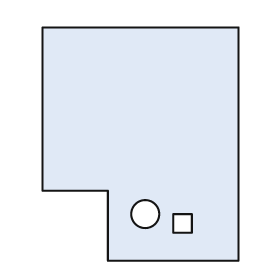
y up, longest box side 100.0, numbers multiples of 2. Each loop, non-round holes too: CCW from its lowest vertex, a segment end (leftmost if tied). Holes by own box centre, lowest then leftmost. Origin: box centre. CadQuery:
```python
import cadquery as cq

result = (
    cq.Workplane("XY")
    .moveTo(-14.0, -50.0)
    .lineTo(42.0, -50.0)
    .lineTo(42.0, 50.0)
    .lineTo(-42.0, 50.0)
    .lineTo(-42.0, -20.0)
    .lineTo(-14.0, -20.0)
    .close()
    .moveTo(14.0, -38.0)
    .lineTo(22.0, -38.0)
    .lineTo(22.0, -30.0)
    .lineTo(14.0, -30.0)
    .close()
    .moveTo(2.0, -30.0)
    .circle(6.0)
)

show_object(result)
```